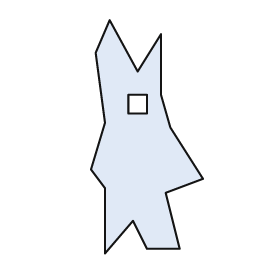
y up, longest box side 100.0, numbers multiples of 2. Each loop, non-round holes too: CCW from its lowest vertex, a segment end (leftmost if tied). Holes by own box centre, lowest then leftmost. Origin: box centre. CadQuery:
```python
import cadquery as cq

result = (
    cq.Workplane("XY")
    .moveTo(-18.0, -50.0)
    .lineTo(-6.0, -36.0)
    .lineTo(0.0, -48.0)
    .lineTo(14.0, -48.0)
    .lineTo(8.0, -24.0)
    .lineTo(24.0, -18.0)
    .lineTo(10.0, 4.0)
    .lineTo(6.0, 18.0)
    .lineTo(6.0, 44.0)
    .lineTo(-4.0, 28.0)
    .lineTo(-16.0, 50.0)
    .lineTo(-22.0, 36.0)
    .lineTo(-18.0, 6.0)
    .lineTo(-24.0, -14.0)
    .lineTo(-18.0, -22.0)
    .close()
    .moveTo(-8.0, 10.0)
    .lineTo(0.0, 10.0)
    .lineTo(0.0, 18.0)
    .lineTo(-8.0, 18.0)
    .close()
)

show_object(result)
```